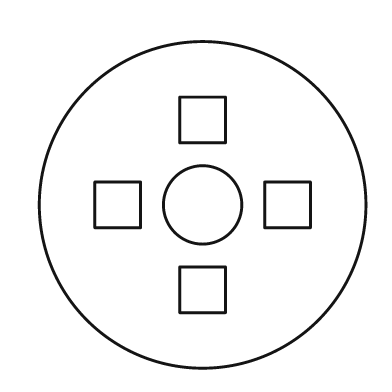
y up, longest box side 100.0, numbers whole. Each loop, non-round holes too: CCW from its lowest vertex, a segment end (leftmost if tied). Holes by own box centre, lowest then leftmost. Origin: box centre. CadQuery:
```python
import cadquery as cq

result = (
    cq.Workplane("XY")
    .moveTo(0.0, 0.0)
    .circle(50.0)
    .moveTo(-7.0, -33.0)
    .lineTo(7.0, -33.0)
    .lineTo(7.0, -19.0)
    .lineTo(-7.0, -19.0)
    .close()
    .moveTo(-33.0, -7.0)
    .lineTo(-19.0, -7.0)
    .lineTo(-19.0, 7.0)
    .lineTo(-33.0, 7.0)
    .close()
    .moveTo(0.0, 0.0)
    .circle(12.0)
    .moveTo(19.0, -7.0)
    .lineTo(33.0, -7.0)
    .lineTo(33.0, 7.0)
    .lineTo(19.0, 7.0)
    .close()
    .moveTo(-7.0, 19.0)
    .lineTo(7.0, 19.0)
    .lineTo(7.0, 33.0)
    .lineTo(-7.0, 33.0)
    .close()
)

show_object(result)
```